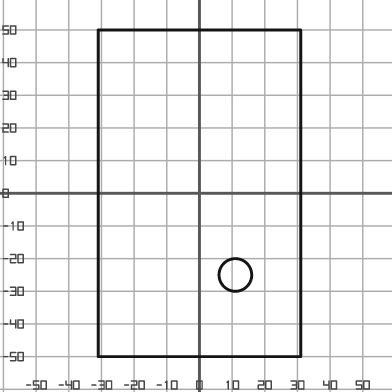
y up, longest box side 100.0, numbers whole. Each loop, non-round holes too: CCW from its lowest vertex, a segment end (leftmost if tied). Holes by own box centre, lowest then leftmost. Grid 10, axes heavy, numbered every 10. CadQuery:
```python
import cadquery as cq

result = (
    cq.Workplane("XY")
    .moveTo(-31.0, -50.0)
    .lineTo(31.0, -50.0)
    .lineTo(31.0, 50.0)
    .lineTo(-31.0, 50.0)
    .close()
    .moveTo(11.0, -25.0)
    .circle(5.0)
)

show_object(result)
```